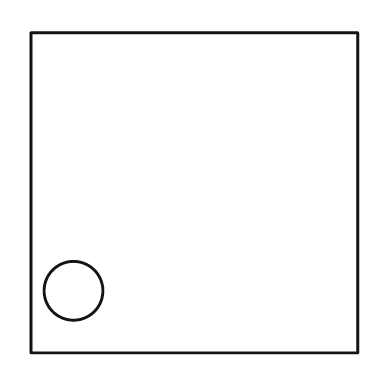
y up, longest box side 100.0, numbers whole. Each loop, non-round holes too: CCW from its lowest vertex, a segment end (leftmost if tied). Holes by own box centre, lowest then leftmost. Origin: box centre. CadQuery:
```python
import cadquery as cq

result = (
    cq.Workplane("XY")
    .moveTo(-50.0, -49.0)
    .lineTo(50.0, -49.0)
    .lineTo(50.0, 49.0)
    .lineTo(-50.0, 49.0)
    .close()
    .moveTo(-37.0, -30.0)
    .circle(9.0)
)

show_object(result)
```